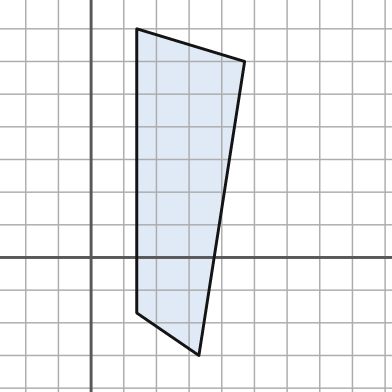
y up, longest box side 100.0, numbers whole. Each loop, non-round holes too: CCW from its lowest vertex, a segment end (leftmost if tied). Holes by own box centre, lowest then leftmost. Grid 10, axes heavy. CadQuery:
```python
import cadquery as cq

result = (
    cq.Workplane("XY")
    .moveTo(33.0, -30.0)
    .lineTo(47.0, 60.0)
    .lineTo(14.0, 70.0)
    .lineTo(14.0, -17.0)
    .close()
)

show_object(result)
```